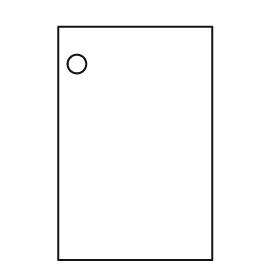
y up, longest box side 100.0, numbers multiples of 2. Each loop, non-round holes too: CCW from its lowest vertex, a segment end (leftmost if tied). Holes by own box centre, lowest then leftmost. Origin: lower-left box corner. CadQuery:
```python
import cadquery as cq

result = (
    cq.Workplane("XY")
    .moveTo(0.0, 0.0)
    .lineTo(66.0, 0.0)
    .lineTo(66.0, 100.0)
    .lineTo(0.0, 100.0)
    .close()
    .moveTo(8.0, 84.0)
    .circle(4.0)
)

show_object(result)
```